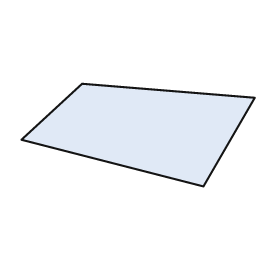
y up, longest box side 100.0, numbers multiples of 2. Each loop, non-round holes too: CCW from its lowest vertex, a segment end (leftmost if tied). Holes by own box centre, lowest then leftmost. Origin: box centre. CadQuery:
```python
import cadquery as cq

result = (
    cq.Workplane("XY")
    .moveTo(28.0, -22.0)
    .lineTo(50.0, 16.0)
    .lineTo(-24.0, 22.0)
    .lineTo(-50.0, -2.0)
    .close()
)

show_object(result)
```